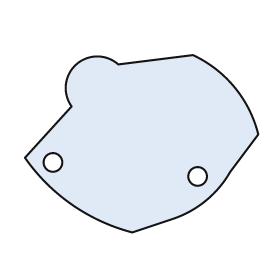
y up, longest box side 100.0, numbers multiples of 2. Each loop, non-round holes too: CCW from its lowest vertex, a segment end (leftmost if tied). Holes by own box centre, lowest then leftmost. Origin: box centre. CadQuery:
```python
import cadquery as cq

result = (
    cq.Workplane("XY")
    .moveTo(-4.0, -38.0)
    .lineTo(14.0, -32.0)
    .threePointArc((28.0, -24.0), (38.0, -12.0))
    .lineTo(50.0, 4.0)
    .threePointArc((40.0, 24.0), (22.0, 38.0))
    .lineTo(-10.0, 34.0)
    .threePointArc((-28.0, 34.0), (-30.0, 16.0))
    .lineTo(-50.0, -6.0)
    .threePointArc((-30.0, -26.0), (-4.0, -38.0))
    .close()
    .moveTo(24.0, -14.0)
    .circle(4.0)
    .moveTo(-38.0, -8.0)
    .circle(4.0)
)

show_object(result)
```